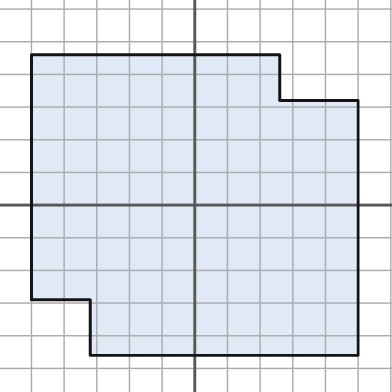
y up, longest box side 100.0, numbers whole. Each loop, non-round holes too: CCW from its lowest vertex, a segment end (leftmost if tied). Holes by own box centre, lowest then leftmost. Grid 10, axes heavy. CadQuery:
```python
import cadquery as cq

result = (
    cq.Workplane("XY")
    .moveTo(-32.0, -46.0)
    .lineTo(50.0, -46.0)
    .lineTo(50.0, 32.0)
    .lineTo(26.0, 32.0)
    .lineTo(26.0, 46.0)
    .lineTo(-50.0, 46.0)
    .lineTo(-50.0, -29.0)
    .lineTo(-32.0, -29.0)
    .close()
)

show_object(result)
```